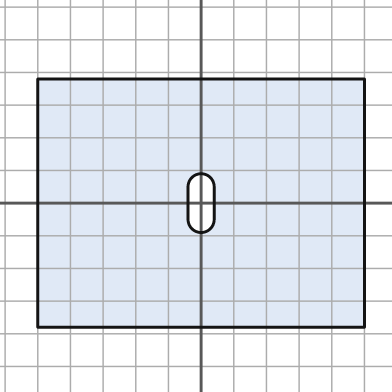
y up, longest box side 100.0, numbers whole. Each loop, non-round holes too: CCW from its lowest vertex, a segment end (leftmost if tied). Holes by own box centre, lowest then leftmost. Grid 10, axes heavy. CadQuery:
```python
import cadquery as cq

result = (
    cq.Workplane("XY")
    .moveTo(-50.0, -38.0)
    .lineTo(50.0, -38.0)
    .lineTo(50.0, 38.0)
    .lineTo(-50.0, 38.0)
    .close()
    .moveTo(-4.0, -5.0)
    .threePointArc((0.0, -9.0), (4.0, -5.0))
    .lineTo(4.0, 5.0)
    .threePointArc((0.0, 9.0), (-4.0, 5.0))
    .close()
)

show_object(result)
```